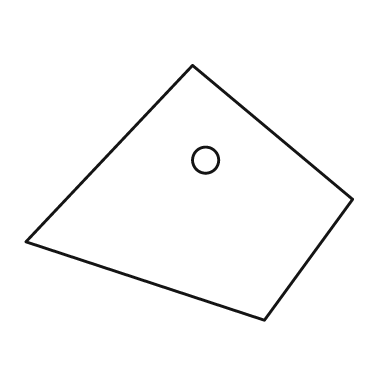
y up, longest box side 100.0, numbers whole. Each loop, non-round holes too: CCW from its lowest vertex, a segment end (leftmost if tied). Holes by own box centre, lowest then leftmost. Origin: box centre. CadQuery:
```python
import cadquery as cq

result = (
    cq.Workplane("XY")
    .moveTo(23.0, -39.0)
    .lineTo(50.0, -2.0)
    .lineTo(1.0, 39.0)
    .lineTo(-50.0, -15.0)
    .close()
    .moveTo(5.0, 10.0)
    .circle(4.0)
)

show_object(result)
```